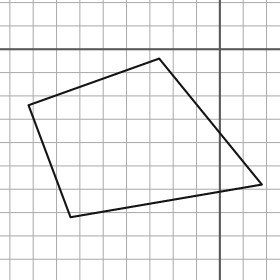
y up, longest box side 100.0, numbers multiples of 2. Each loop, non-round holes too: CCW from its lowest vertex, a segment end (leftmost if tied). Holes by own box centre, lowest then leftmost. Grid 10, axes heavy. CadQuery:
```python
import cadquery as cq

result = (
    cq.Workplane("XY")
    .moveTo(-64.0, -72.0)
    .lineTo(18.0, -58.0)
    .lineTo(-26.0, -4.0)
    .lineTo(-82.0, -24.0)
    .close()
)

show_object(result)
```